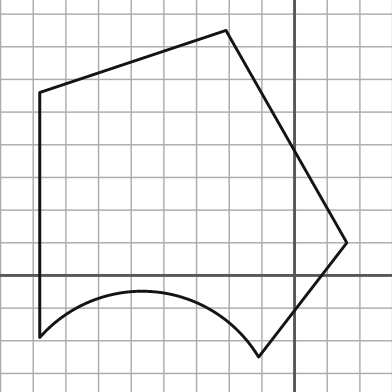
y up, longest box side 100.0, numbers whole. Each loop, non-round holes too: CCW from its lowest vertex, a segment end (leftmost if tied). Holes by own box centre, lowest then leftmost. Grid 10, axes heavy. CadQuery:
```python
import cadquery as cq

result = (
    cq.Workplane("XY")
    .moveTo(-11.0, -25.0)
    .lineTo(16.0, 10.0)
    .lineTo(-21.0, 75.0)
    .lineTo(-78.0, 56.0)
    .lineTo(-78.0, -19.0)
    .threePointArc((-43.0, -5.0), (-11.0, -25.0))
    .close()
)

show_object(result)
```